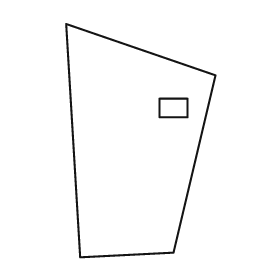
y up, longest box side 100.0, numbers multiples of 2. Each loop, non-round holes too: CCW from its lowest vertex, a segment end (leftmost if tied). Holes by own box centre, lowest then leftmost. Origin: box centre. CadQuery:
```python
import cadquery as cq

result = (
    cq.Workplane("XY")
    .moveTo(-26.0, -50.0)
    .lineTo(14.0, -48.0)
    .lineTo(32.0, 28.0)
    .lineTo(-32.0, 50.0)
    .close()
    .moveTo(8.0, 10.0)
    .lineTo(20.0, 10.0)
    .lineTo(20.0, 18.0)
    .lineTo(8.0, 18.0)
    .close()
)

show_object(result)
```